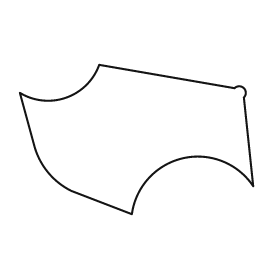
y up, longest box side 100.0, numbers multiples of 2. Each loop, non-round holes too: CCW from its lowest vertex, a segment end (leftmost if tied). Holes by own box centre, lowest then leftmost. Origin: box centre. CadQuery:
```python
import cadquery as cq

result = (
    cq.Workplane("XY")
    .moveTo(-2.0, -32.0)
    .threePointArc((20.0, -8.0), (50.0, -20.0))
    .lineTo(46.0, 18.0)
    .threePointArc((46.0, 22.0), (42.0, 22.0))
    .lineTo(-16.0, 32.0)
    .threePointArc((-30.0, 18.0), (-50.0, 20.0))
    .lineTo(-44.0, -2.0)
    .threePointArc((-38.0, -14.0), (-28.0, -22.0))
    .close()
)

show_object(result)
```